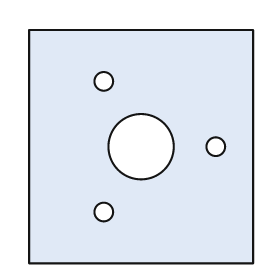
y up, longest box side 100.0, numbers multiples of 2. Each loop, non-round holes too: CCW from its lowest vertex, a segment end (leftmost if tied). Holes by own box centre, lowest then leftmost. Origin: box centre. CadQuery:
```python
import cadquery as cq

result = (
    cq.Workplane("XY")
    .moveTo(-48.0, -50.0)
    .lineTo(48.0, -50.0)
    .lineTo(48.0, 50.0)
    .lineTo(-48.0, 50.0)
    .close()
    .moveTo(-16.0, -28.0)
    .circle(4.0)
    .moveTo(0.0, 0.0)
    .circle(14.0)
    .moveTo(32.0, 0.0)
    .circle(4.0)
    .moveTo(-16.0, 28.0)
    .circle(4.0)
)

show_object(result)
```